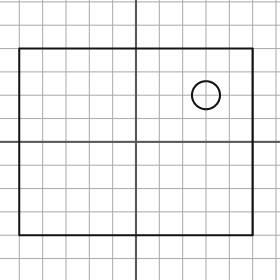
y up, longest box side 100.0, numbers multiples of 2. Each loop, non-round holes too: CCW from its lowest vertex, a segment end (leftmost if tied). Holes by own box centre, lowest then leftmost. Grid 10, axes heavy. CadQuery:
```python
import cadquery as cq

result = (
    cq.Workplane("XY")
    .moveTo(-50.0, -40.0)
    .lineTo(50.0, -40.0)
    .lineTo(50.0, 40.0)
    .lineTo(-50.0, 40.0)
    .close()
    .moveTo(30.0, 20.0)
    .circle(6.0)
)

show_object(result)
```